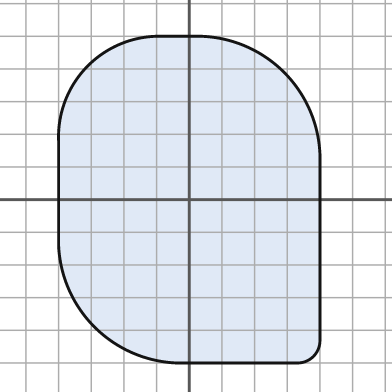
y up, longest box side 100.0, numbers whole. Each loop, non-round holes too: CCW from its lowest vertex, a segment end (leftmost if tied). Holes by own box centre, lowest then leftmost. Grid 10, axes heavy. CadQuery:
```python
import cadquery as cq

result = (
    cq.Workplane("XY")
    .moveTo(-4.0, -50.0)
    .lineTo(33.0, -50.0)
    .threePointArc((38.0, -48.0), (40.0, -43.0))
    .lineTo(40.0, 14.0)
    .threePointArc((29.0, 39.0), (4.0, 50.0))
    .lineTo(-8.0, 50.0)
    .threePointArc((-31.0, 41.0), (-40.0, 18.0))
    .lineTo(-40.0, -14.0)
    .threePointArc((-29.0, -39.0), (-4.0, -50.0))
    .close()
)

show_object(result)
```